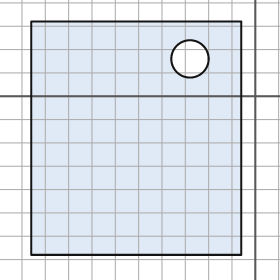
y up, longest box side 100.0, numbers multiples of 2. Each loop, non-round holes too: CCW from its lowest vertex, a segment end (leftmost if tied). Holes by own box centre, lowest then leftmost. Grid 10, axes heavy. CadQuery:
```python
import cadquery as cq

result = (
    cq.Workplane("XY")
    .moveTo(-96.0, -68.0)
    .lineTo(-6.0, -68.0)
    .lineTo(-6.0, 32.0)
    .lineTo(-96.0, 32.0)
    .close()
    .moveTo(-28.0, 16.0)
    .circle(8.0)
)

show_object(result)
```